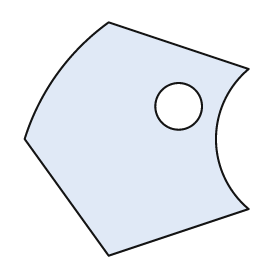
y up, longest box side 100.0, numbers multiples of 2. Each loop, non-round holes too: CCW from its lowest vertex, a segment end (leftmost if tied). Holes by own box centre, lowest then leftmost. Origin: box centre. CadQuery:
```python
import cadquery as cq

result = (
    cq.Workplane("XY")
    .moveTo(-12.0, -50.0)
    .lineTo(48.0, -30.0)
    .threePointArc((34.0, 0.0), (48.0, 30.0))
    .lineTo(-12.0, 50.0)
    .threePointArc((-34.0, 28.0), (-48.0, 0.0))
    .close()
    .moveTo(18.0, 14.0)
    .circle(10.0)
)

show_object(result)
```